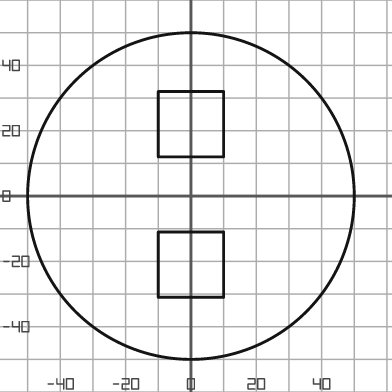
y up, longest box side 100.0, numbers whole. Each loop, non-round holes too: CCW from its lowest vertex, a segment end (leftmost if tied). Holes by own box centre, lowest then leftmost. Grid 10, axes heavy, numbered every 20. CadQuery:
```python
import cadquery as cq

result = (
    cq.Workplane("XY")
    .moveTo(0.0, 0.0)
    .circle(50.0)
    .moveTo(-10.0, -31.0)
    .lineTo(10.0, -31.0)
    .lineTo(10.0, -11.0)
    .lineTo(-10.0, -11.0)
    .close()
    .moveTo(-10.0, 12.0)
    .lineTo(10.0, 12.0)
    .lineTo(10.0, 32.0)
    .lineTo(-10.0, 32.0)
    .close()
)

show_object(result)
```